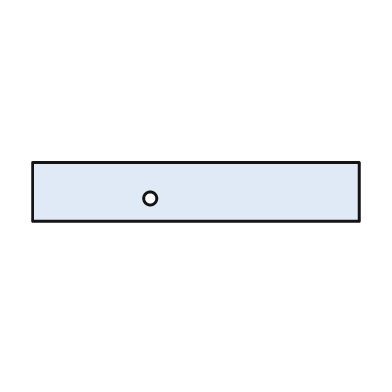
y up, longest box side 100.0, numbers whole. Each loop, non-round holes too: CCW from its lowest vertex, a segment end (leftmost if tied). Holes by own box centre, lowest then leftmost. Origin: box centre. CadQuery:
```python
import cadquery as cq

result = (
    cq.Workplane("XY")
    .moveTo(-50.0, -9.0)
    .lineTo(50.0, -9.0)
    .lineTo(50.0, 9.0)
    .lineTo(-50.0, 9.0)
    .close()
    .moveTo(-14.0, -2.0)
    .circle(2.0)
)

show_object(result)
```